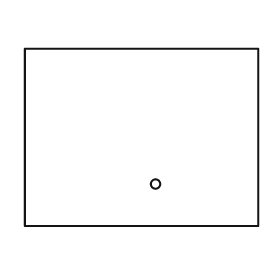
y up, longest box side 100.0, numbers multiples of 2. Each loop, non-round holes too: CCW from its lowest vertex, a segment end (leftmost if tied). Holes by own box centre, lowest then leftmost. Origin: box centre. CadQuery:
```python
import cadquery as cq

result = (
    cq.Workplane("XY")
    .moveTo(-50.0, -38.0)
    .lineTo(50.0, -38.0)
    .lineTo(50.0, 38.0)
    .lineTo(-50.0, 38.0)
    .close()
    .moveTo(6.0, -20.0)
    .circle(2.0)
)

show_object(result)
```